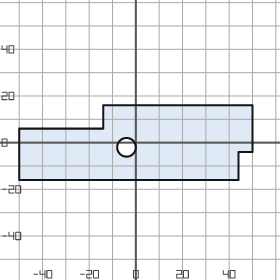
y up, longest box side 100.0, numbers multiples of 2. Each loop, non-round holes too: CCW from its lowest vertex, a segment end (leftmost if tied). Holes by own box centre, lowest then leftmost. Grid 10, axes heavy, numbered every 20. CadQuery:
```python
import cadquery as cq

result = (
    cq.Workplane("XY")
    .moveTo(-50.0, -16.0)
    .lineTo(44.0, -16.0)
    .lineTo(44.0, -4.0)
    .lineTo(50.0, -4.0)
    .lineTo(50.0, 16.0)
    .lineTo(-14.0, 16.0)
    .lineTo(-14.0, 6.0)
    .lineTo(-50.0, 6.0)
    .close()
    .moveTo(-4.0, -2.0)
    .circle(4.0)
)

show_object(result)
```